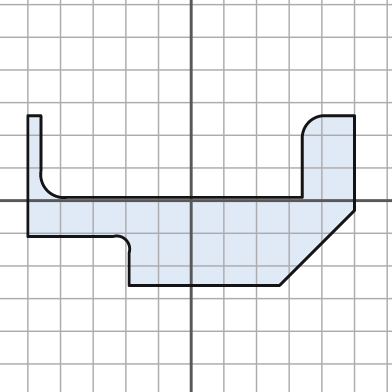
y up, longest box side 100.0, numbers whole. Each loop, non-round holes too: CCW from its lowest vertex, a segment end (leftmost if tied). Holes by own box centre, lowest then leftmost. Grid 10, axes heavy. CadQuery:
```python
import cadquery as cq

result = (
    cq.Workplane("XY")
    .moveTo(-19.0, -26.0)
    .lineTo(27.0, -26.0)
    .lineTo(50.0, -3.0)
    .lineTo(50.0, 26.0)
    .lineTo(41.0, 26.0)
    .threePointArc((36.0, 24.0), (34.0, 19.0))
    .lineTo(34.0, 1.0)
    .lineTo(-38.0, 1.0)
    .threePointArc((-44.0, 3.0), (-46.0, 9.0))
    .lineTo(-46.0, 26.0)
    .lineTo(-50.0, 26.0)
    .lineTo(-50.0, -11.0)
    .lineTo(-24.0, -11.0)
    .threePointArc((-20.0, -12.0), (-19.0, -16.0))
    .close()
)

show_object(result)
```